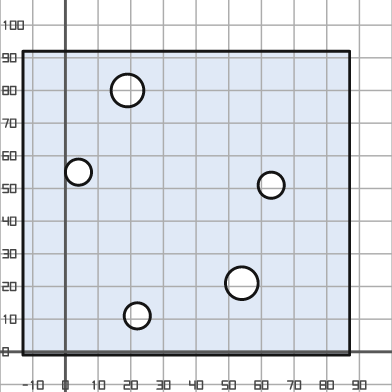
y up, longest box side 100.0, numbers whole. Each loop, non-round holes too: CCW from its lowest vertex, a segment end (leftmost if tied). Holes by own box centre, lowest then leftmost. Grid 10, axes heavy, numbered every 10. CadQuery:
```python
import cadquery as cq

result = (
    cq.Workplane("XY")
    .moveTo(-13.0, -1.0)
    .lineTo(87.0, -1.0)
    .lineTo(87.0, 92.0)
    .lineTo(-13.0, 92.0)
    .close()
    .moveTo(22.0, 11.0)
    .circle(4.0)
    .moveTo(54.0, 21.0)
    .circle(5.0)
    .moveTo(63.0, 51.0)
    .circle(4.0)
    .moveTo(4.0, 55.0)
    .circle(4.0)
    .moveTo(19.0, 80.0)
    .circle(5.0)
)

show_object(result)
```